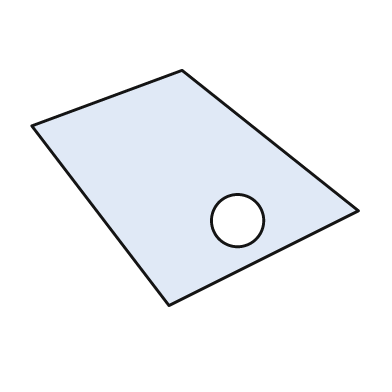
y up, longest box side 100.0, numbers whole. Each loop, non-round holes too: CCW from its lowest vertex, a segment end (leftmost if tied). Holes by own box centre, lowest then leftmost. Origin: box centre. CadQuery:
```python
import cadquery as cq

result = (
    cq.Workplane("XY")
    .moveTo(-8.0, -36.0)
    .lineTo(50.0, -7.0)
    .lineTo(-4.0, 36.0)
    .lineTo(-50.0, 19.0)
    .close()
    .moveTo(13.0, -10.0)
    .circle(8.0)
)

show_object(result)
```